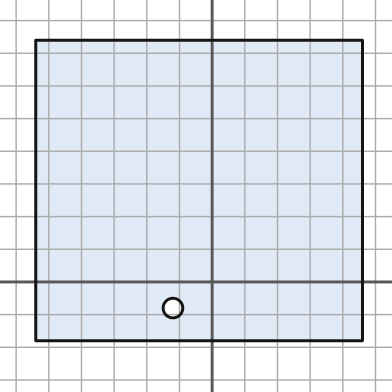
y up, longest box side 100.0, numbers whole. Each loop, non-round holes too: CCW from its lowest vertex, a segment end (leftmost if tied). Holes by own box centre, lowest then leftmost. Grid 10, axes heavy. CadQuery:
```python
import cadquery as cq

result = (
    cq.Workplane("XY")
    .moveTo(-54.0, -18.0)
    .lineTo(46.0, -18.0)
    .lineTo(46.0, 74.0)
    .lineTo(-54.0, 74.0)
    .close()
    .moveTo(-12.0, -8.0)
    .circle(3.0)
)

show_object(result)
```